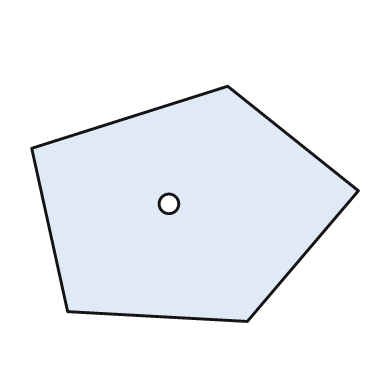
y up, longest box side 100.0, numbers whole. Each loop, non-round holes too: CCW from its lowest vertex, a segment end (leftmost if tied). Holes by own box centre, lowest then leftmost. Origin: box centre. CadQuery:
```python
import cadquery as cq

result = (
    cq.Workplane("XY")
    .moveTo(16.0, -36.0)
    .lineTo(50.0, 4.0)
    .lineTo(10.0, 36.0)
    .lineTo(-50.0, 17.0)
    .lineTo(-39.0, -33.0)
    .close()
    .moveTo(-8.0, 0.0)
    .circle(3.0)
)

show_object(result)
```